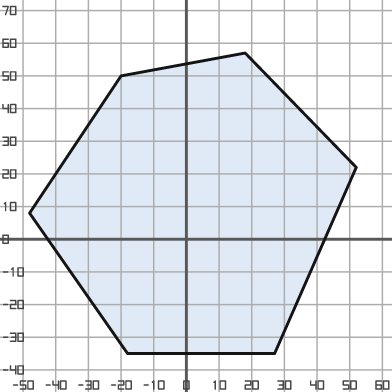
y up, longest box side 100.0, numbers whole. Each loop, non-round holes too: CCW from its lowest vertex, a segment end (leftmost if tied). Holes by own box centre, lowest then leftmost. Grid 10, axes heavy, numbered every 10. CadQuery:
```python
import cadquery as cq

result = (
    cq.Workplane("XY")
    .moveTo(-18.0, -35.0)
    .lineTo(27.0, -35.0)
    .lineTo(52.0, 22.0)
    .lineTo(18.0, 57.0)
    .lineTo(-20.0, 50.0)
    .lineTo(-48.0, 8.0)
    .close()
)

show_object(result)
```